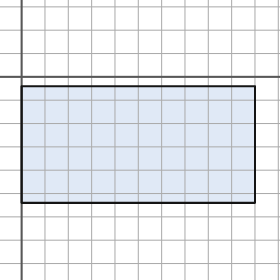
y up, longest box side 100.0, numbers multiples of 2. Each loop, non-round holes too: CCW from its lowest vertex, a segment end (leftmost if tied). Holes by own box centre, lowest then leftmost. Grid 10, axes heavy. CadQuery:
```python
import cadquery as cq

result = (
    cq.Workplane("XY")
    .moveTo(0.0, -54.0)
    .lineTo(100.0, -54.0)
    .lineTo(100.0, -4.0)
    .lineTo(0.0, -4.0)
    .close()
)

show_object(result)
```